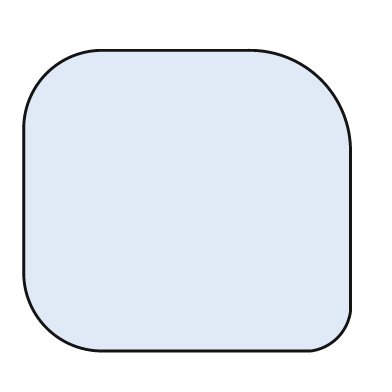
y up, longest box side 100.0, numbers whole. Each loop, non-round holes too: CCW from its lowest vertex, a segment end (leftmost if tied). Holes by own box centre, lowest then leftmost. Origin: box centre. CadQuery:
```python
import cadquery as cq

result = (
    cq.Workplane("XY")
    .moveTo(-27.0, -46.0)
    .lineTo(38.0, -46.0)
    .threePointArc((46.0, -42.0), (50.0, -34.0))
    .lineTo(50.0, 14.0)
    .threePointArc((41.0, 37.0), (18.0, 46.0))
    .lineTo(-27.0, 46.0)
    .threePointArc((-43.0, 39.0), (-50.0, 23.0))
    .lineTo(-50.0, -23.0)
    .threePointArc((-43.0, -39.0), (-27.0, -46.0))
    .close()
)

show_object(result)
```